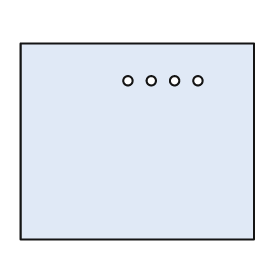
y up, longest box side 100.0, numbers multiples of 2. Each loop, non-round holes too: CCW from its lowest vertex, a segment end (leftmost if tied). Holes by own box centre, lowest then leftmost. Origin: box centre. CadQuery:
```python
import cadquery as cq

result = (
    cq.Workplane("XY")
    .moveTo(-50.0, -42.0)
    .lineTo(50.0, -42.0)
    .lineTo(50.0, 42.0)
    .lineTo(-50.0, 42.0)
    .close()
    .moveTo(-4.0, 26.0)
    .circle(2.0)
    .moveTo(6.0, 26.0)
    .circle(2.0)
    .moveTo(16.0, 26.0)
    .circle(2.0)
    .moveTo(26.0, 26.0)
    .circle(2.0)
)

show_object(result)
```